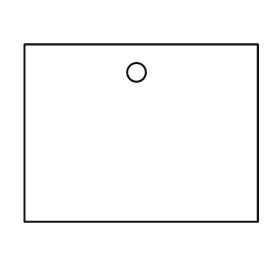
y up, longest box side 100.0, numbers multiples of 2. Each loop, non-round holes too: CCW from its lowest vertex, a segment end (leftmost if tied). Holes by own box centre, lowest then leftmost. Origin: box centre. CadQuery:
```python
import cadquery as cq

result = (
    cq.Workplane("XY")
    .moveTo(-50.0, -38.0)
    .lineTo(50.0, -38.0)
    .lineTo(50.0, 38.0)
    .lineTo(-50.0, 38.0)
    .close()
    .moveTo(-2.0, 26.0)
    .circle(4.0)
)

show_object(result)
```